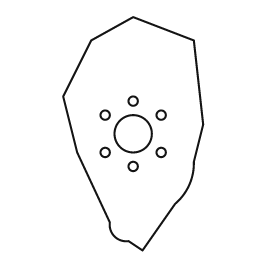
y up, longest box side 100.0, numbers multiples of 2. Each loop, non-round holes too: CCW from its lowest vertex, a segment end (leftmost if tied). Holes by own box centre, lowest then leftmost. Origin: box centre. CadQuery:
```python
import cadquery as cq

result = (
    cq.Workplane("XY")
    .moveTo(4.0, -50.0)
    .lineTo(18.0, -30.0)
    .threePointArc((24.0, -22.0), (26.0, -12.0))
    .lineTo(30.0, 4.0)
    .lineTo(26.0, 40.0)
    .lineTo(0.0, 50.0)
    .lineTo(-18.0, 40.0)
    .lineTo(-30.0, 16.0)
    .lineTo(-24.0, -8.0)
    .lineTo(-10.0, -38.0)
    .threePointArc((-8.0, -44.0), (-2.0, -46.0))
    .close()
    .moveTo(0.0, -14.0)
    .circle(2.0)
    .moveTo(-12.0, -8.0)
    .circle(2.0)
    .moveTo(12.0, -8.0)
    .circle(2.0)
    .moveTo(0.0, 0.0)
    .circle(8.0)
    .moveTo(-12.0, 8.0)
    .circle(2.0)
    .moveTo(12.0, 8.0)
    .circle(2.0)
    .moveTo(0.0, 14.0)
    .circle(2.0)
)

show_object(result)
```